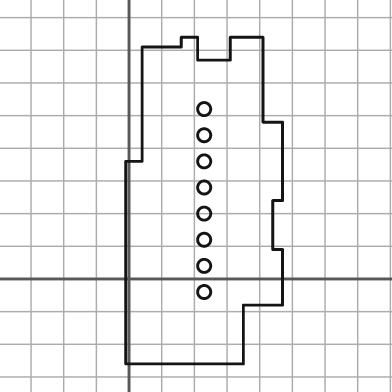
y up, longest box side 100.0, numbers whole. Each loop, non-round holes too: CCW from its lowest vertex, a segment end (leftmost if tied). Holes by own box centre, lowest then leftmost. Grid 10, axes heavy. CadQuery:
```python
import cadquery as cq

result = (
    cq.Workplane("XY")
    .moveTo(-1.0, -26.0)
    .lineTo(35.0, -26.0)
    .lineTo(35.0, -8.0)
    .lineTo(47.0, -8.0)
    .lineTo(47.0, 9.0)
    .lineTo(44.0, 9.0)
    .lineTo(44.0, 24.0)
    .lineTo(47.0, 24.0)
    .lineTo(47.0, 48.0)
    .lineTo(41.0, 48.0)
    .lineTo(41.0, 74.0)
    .lineTo(31.0, 74.0)
    .lineTo(31.0, 67.0)
    .lineTo(21.0, 67.0)
    .lineTo(21.0, 74.0)
    .lineTo(16.0, 74.0)
    .lineTo(16.0, 71.0)
    .lineTo(4.0, 71.0)
    .lineTo(4.0, 36.0)
    .lineTo(-1.0, 36.0)
    .close()
    .moveTo(23.0, -4.0)
    .circle(2.0)
    .moveTo(23.0, 4.0)
    .circle(2.0)
    .moveTo(23.0, 12.0)
    .circle(2.0)
    .moveTo(23.0, 20.0)
    .circle(2.0)
    .moveTo(23.0, 28.0)
    .circle(2.0)
    .moveTo(23.0, 36.0)
    .circle(2.0)
    .moveTo(23.0, 44.0)
    .circle(2.0)
    .moveTo(23.0, 52.0)
    .circle(2.0)
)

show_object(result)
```